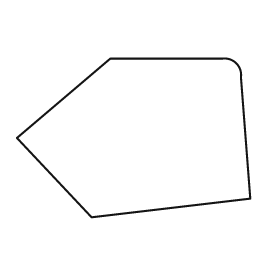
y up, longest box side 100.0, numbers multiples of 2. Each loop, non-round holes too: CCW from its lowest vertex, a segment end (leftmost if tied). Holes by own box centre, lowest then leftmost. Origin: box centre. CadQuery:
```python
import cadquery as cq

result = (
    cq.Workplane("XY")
    .moveTo(-18.0, -34.0)
    .lineTo(50.0, -26.0)
    .lineTo(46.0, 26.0)
    .threePointArc((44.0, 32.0), (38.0, 34.0))
    .lineTo(-10.0, 34.0)
    .lineTo(-50.0, 0.0)
    .close()
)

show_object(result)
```